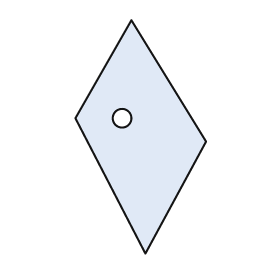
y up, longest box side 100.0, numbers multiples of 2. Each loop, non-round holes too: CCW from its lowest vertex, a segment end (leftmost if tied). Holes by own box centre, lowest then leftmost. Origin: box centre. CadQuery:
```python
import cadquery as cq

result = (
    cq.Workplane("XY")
    .moveTo(2.0, -50.0)
    .lineTo(28.0, -2.0)
    .lineTo(-4.0, 50.0)
    .lineTo(-28.0, 8.0)
    .close()
    .moveTo(-8.0, 8.0)
    .circle(4.0)
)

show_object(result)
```